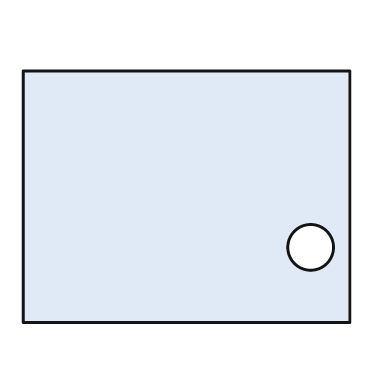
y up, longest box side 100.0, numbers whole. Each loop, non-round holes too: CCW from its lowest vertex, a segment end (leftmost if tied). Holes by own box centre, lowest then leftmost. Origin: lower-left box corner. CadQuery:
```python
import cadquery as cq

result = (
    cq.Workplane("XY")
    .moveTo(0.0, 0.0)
    .lineTo(100.0, 0.0)
    .lineTo(100.0, 77.0)
    .lineTo(0.0, 77.0)
    .close()
    .moveTo(88.0, 23.0)
    .circle(7.0)
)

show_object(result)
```